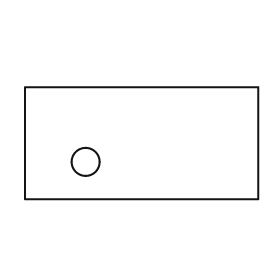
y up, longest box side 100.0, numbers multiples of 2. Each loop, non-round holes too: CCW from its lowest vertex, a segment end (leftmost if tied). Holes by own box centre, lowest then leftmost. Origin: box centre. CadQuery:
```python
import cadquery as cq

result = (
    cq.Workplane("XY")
    .moveTo(-50.0, -24.0)
    .lineTo(50.0, -24.0)
    .lineTo(50.0, 24.0)
    .lineTo(-50.0, 24.0)
    .close()
    .moveTo(-24.0, -8.0)
    .circle(6.0)
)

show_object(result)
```